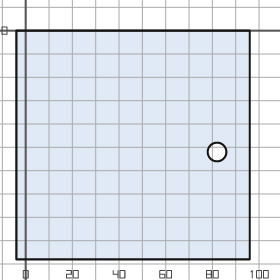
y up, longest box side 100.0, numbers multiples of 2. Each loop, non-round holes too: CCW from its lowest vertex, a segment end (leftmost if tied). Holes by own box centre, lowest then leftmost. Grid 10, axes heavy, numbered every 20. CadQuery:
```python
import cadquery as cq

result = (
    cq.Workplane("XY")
    .moveTo(-4.0, -98.0)
    .lineTo(96.0, -98.0)
    .lineTo(96.0, 0.0)
    .lineTo(-4.0, 0.0)
    .close()
    .moveTo(82.0, -52.0)
    .circle(4.0)
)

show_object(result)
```